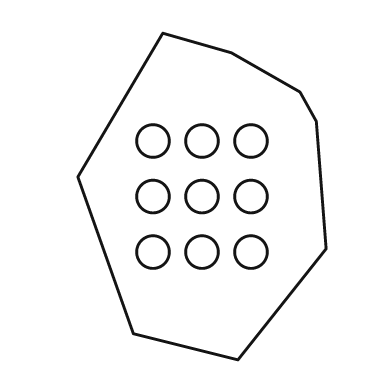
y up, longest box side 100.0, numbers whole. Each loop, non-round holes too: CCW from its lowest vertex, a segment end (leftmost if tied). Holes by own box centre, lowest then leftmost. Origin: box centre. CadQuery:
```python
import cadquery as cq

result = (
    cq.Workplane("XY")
    .moveTo(11.0, -50.0)
    .lineTo(38.0, -16.0)
    .lineTo(35.0, 23.0)
    .lineTo(30.0, 32.0)
    .lineTo(9.0, 44.0)
    .lineTo(-12.0, 50.0)
    .lineTo(-38.0, 6.0)
    .lineTo(-21.0, -42.0)
    .close()
    .moveTo(-15.0, -17.0)
    .circle(5.0)
    .moveTo(0.0, -17.0)
    .circle(5.0)
    .moveTo(15.0, -17.0)
    .circle(5.0)
    .moveTo(-15.0, 0.0)
    .circle(5.0)
    .moveTo(0.0, 0.0)
    .circle(5.0)
    .moveTo(15.0, 0.0)
    .circle(5.0)
    .moveTo(-15.0, 17.0)
    .circle(5.0)
    .moveTo(0.0, 17.0)
    .circle(5.0)
    .moveTo(15.0, 17.0)
    .circle(5.0)
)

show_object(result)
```